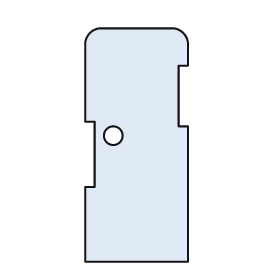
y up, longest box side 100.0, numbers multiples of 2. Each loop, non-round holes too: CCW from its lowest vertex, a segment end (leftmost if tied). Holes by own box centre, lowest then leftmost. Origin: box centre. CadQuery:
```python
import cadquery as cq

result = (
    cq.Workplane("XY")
    .moveTo(-22.0, -50.0)
    .lineTo(22.0, -50.0)
    .lineTo(22.0, 8.0)
    .lineTo(18.0, 8.0)
    .lineTo(18.0, 34.0)
    .lineTo(22.0, 34.0)
    .lineTo(22.0, 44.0)
    .threePointArc((20.0, 48.0), (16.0, 50.0))
    .lineTo(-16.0, 50.0)
    .threePointArc((-20.0, 48.0), (-22.0, 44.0))
    .lineTo(-22.0, 10.0)
    .lineTo(-18.0, 10.0)
    .lineTo(-18.0, -18.0)
    .lineTo(-22.0, -18.0)
    .close()
    .moveTo(-10.0, 4.0)
    .circle(4.0)
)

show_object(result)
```